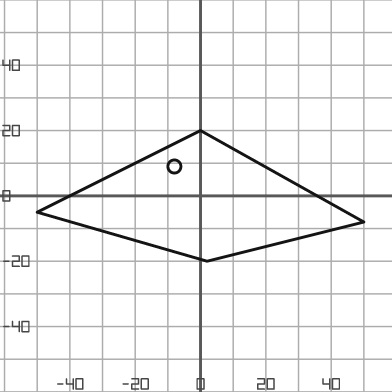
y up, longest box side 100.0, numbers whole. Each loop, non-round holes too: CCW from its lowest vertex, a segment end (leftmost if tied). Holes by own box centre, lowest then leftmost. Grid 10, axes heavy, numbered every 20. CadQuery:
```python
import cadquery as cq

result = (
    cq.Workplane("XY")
    .moveTo(2.0, -20.0)
    .lineTo(50.0, -8.0)
    .lineTo(0.0, 20.0)
    .lineTo(-50.0, -5.0)
    .close()
    .moveTo(-8.0, 9.0)
    .circle(2.0)
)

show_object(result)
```